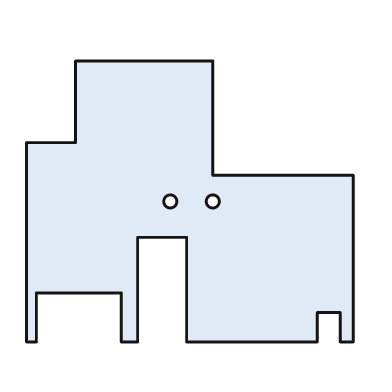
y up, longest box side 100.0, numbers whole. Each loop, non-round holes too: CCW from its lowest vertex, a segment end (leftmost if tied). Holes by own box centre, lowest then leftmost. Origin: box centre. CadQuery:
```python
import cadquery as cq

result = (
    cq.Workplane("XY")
    .moveTo(-50.0, -43.0)
    .lineTo(-47.0, -43.0)
    .lineTo(-47.0, -28.0)
    .lineTo(-21.0, -28.0)
    .lineTo(-21.0, -43.0)
    .lineTo(-16.0, -43.0)
    .lineTo(-16.0, -11.0)
    .lineTo(-1.0, -11.0)
    .lineTo(-1.0, -43.0)
    .lineTo(39.0, -43.0)
    .lineTo(39.0, -34.0)
    .lineTo(46.0, -34.0)
    .lineTo(46.0, -43.0)
    .lineTo(50.0, -43.0)
    .lineTo(50.0, 8.0)
    .lineTo(7.0, 8.0)
    .lineTo(7.0, 43.0)
    .lineTo(-35.0, 43.0)
    .lineTo(-35.0, 18.0)
    .lineTo(-50.0, 18.0)
    .close()
    .moveTo(-6.0, 0.0)
    .circle(2.0)
    .moveTo(7.0, 0.0)
    .circle(2.0)
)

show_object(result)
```